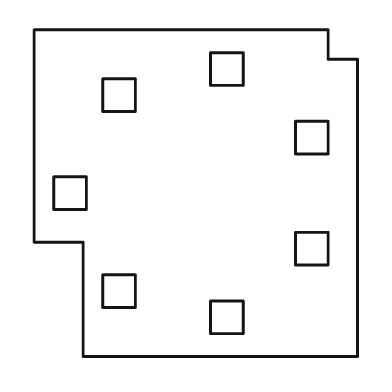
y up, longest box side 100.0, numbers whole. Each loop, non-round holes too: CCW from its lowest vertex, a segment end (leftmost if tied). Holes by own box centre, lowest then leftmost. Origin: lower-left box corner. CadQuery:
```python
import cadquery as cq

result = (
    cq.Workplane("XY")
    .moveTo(15.0, 0.0)
    .lineTo(99.0, 0.0)
    .lineTo(99.0, 91.0)
    .lineTo(90.0, 91.0)
    .lineTo(90.0, 100.0)
    .lineTo(0.0, 100.0)
    .lineTo(0.0, 35.0)
    .lineTo(15.0, 35.0)
    .close()
    .moveTo(54.0, 7.0)
    .lineTo(64.0, 7.0)
    .lineTo(64.0, 17.0)
    .lineTo(54.0, 17.0)
    .close()
    .moveTo(21.0, 15.0)
    .lineTo(31.0, 15.0)
    .lineTo(31.0, 25.0)
    .lineTo(21.0, 25.0)
    .close()
    .moveTo(80.0, 28.0)
    .lineTo(90.0, 28.0)
    .lineTo(90.0, 38.0)
    .lineTo(80.0, 38.0)
    .close()
    .moveTo(6.0, 45.0)
    .lineTo(16.0, 45.0)
    .lineTo(16.0, 55.0)
    .lineTo(6.0, 55.0)
    .close()
    .moveTo(80.0, 62.0)
    .lineTo(90.0, 62.0)
    .lineTo(90.0, 72.0)
    .lineTo(80.0, 72.0)
    .close()
    .moveTo(21.0, 75.0)
    .lineTo(31.0, 75.0)
    .lineTo(31.0, 85.0)
    .lineTo(21.0, 85.0)
    .close()
    .moveTo(54.0, 83.0)
    .lineTo(64.0, 83.0)
    .lineTo(64.0, 93.0)
    .lineTo(54.0, 93.0)
    .close()
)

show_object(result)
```